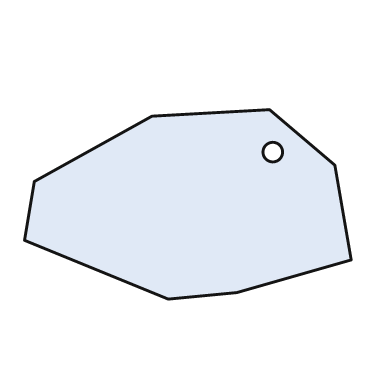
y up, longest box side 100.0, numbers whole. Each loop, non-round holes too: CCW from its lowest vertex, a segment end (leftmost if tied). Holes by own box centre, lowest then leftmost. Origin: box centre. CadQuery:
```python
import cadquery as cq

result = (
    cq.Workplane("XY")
    .moveTo(-6.0, -29.0)
    .lineTo(15.0, -27.0)
    .lineTo(50.0, -17.0)
    .lineTo(45.0, 12.0)
    .lineTo(25.0, 29.0)
    .lineTo(-11.0, 27.0)
    .lineTo(-47.0, 7.0)
    .lineTo(-50.0, -11.0)
    .close()
    .moveTo(26.0, 16.0)
    .circle(3.0)
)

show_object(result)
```